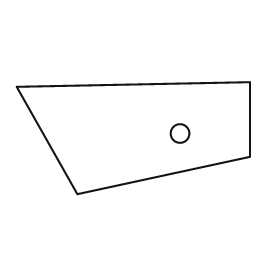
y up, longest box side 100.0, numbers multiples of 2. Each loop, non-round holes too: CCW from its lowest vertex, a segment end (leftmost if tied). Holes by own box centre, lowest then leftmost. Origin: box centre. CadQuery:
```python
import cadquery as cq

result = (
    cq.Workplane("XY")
    .moveTo(-24.0, -24.0)
    .lineTo(50.0, -8.0)
    .lineTo(50.0, 24.0)
    .lineTo(-50.0, 22.0)
    .close()
    .moveTo(20.0, 2.0)
    .circle(4.0)
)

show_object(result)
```